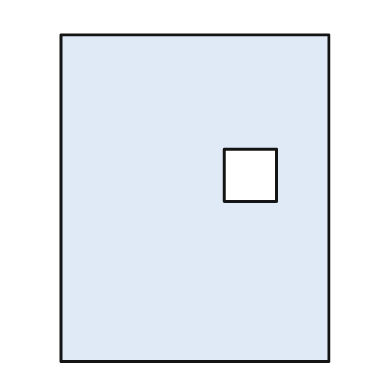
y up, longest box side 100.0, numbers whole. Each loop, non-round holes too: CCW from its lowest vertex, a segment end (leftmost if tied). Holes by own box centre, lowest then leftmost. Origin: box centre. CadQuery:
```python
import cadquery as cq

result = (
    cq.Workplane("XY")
    .moveTo(-41.0, -50.0)
    .lineTo(41.0, -50.0)
    .lineTo(41.0, 50.0)
    .lineTo(-41.0, 50.0)
    .close()
    .moveTo(9.0, -1.0)
    .lineTo(25.0, -1.0)
    .lineTo(25.0, 15.0)
    .lineTo(9.0, 15.0)
    .close()
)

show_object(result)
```